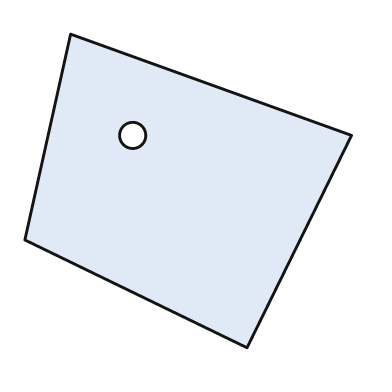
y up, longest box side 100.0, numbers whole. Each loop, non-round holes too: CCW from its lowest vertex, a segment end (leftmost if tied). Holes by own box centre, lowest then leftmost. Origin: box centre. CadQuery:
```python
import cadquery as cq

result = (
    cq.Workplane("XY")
    .moveTo(18.0, -48.0)
    .lineTo(50.0, 17.0)
    .lineTo(-36.0, 48.0)
    .lineTo(-50.0, -15.0)
    .close()
    .moveTo(-17.0, 17.0)
    .circle(4.0)
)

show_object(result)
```